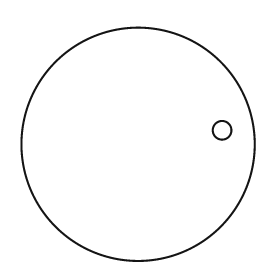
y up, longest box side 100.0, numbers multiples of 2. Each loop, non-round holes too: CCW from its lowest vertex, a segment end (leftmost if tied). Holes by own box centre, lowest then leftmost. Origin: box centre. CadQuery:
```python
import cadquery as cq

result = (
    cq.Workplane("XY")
    .moveTo(0.0, 0.0)
    .circle(50.0)
    .moveTo(36.0, 6.0)
    .circle(4.0)
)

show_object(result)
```